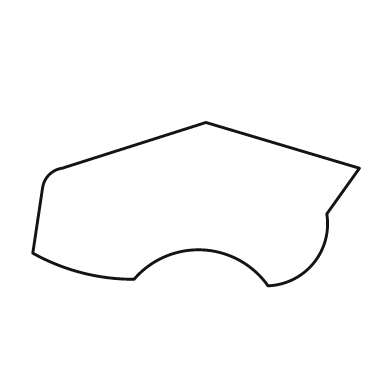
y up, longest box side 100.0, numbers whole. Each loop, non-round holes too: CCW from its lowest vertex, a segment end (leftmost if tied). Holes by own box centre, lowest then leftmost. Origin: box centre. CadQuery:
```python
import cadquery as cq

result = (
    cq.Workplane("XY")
    .moveTo(22.0, -25.0)
    .threePointArc((36.0, -18.0), (40.0, -3.0))
    .lineTo(50.0, 11.0)
    .lineTo(3.0, 25.0)
    .lineTo(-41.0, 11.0)
    .threePointArc((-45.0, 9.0), (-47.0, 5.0))
    .lineTo(-50.0, -15.0)
    .threePointArc((-35.0, -21.0), (-19.0, -23.0))
    .threePointArc((2.0, -14.0), (22.0, -25.0))
    .close()
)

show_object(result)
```